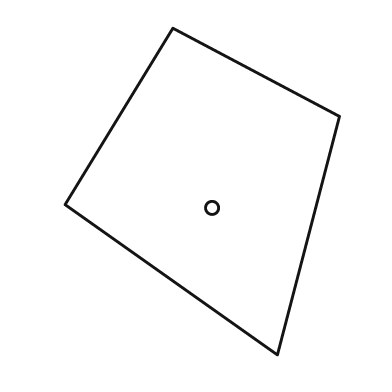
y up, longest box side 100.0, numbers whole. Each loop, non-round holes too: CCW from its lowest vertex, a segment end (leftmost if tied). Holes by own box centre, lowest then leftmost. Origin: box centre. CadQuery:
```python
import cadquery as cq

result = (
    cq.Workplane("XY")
    .moveTo(23.0, -50.0)
    .lineTo(42.0, 23.0)
    .lineTo(-9.0, 50.0)
    .lineTo(-42.0, -4.0)
    .close()
    .moveTo(3.0, -5.0)
    .circle(2.0)
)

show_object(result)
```